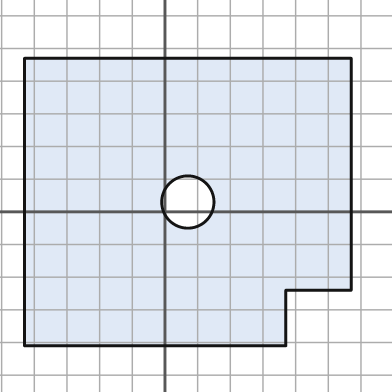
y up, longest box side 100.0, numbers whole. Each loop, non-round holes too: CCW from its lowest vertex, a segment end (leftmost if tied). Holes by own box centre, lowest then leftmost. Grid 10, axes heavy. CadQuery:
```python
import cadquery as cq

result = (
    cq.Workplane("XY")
    .moveTo(-43.0, -41.0)
    .lineTo(37.0, -41.0)
    .lineTo(37.0, -24.0)
    .lineTo(57.0, -24.0)
    .lineTo(57.0, 47.0)
    .lineTo(-43.0, 47.0)
    .close()
    .moveTo(7.0, 3.0)
    .circle(8.0)
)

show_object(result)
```